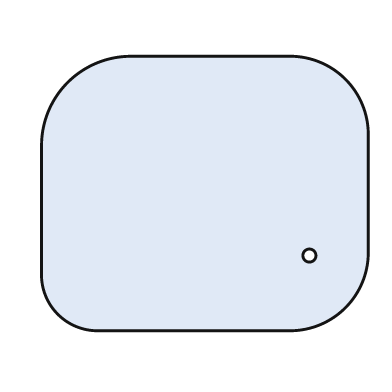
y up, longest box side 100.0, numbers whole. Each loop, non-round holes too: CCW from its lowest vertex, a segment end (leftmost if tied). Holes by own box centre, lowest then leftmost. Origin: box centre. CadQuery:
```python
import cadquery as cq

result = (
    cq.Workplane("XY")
    .moveTo(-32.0, -42.0)
    .lineTo(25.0, -42.0)
    .threePointArc((43.0, -35.0), (50.0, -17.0))
    .lineTo(50.0, 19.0)
    .threePointArc((43.0, 35.0), (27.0, 42.0))
    .lineTo(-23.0, 42.0)
    .threePointArc((-42.0, 34.0), (-50.0, 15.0))
    .lineTo(-50.0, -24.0)
    .threePointArc((-45.0, -37.0), (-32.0, -42.0))
    .close()
    .moveTo(32.0, -19.0)
    .circle(2.0)
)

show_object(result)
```